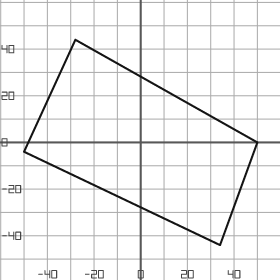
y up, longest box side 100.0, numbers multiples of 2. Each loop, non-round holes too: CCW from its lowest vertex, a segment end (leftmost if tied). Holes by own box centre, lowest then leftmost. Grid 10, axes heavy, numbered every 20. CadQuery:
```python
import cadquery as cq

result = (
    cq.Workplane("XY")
    .moveTo(34.0, -44.0)
    .lineTo(50.0, 0.0)
    .lineTo(-28.0, 44.0)
    .lineTo(-50.0, -4.0)
    .close()
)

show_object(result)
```